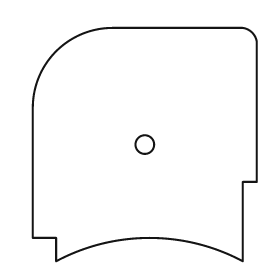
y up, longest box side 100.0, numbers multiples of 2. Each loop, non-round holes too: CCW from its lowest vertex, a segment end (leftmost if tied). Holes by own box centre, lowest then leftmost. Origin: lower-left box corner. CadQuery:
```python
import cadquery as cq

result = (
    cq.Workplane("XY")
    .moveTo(10.0, 0.0)
    .threePointArc((50.0, 10.0), (90.0, 0.0))
    .lineTo(90.0, 34.0)
    .lineTo(96.0, 34.0)
    .lineTo(96.0, 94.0)
    .threePointArc((94.0, 98.0), (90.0, 100.0))
    .lineTo(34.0, 100.0)
    .threePointArc((10.0, 90.0), (0.0, 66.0))
    .lineTo(0.0, 10.0)
    .lineTo(10.0, 10.0)
    .close()
    .moveTo(48.0, 50.0)
    .circle(4.0)
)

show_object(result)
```